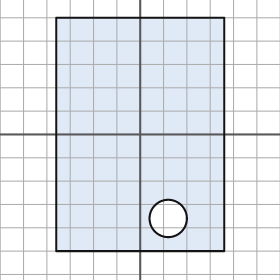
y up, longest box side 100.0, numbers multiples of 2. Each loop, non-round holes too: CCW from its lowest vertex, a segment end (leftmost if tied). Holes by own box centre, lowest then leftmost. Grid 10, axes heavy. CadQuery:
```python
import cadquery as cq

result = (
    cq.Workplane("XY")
    .moveTo(-36.0, -50.0)
    .lineTo(36.0, -50.0)
    .lineTo(36.0, 50.0)
    .lineTo(-36.0, 50.0)
    .close()
    .moveTo(12.0, -36.0)
    .circle(8.0)
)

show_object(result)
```